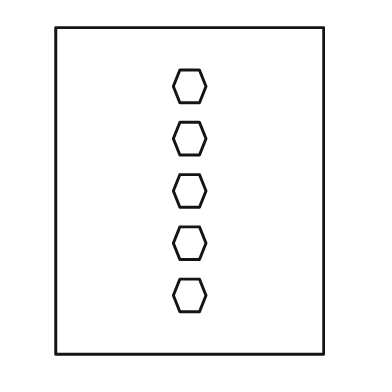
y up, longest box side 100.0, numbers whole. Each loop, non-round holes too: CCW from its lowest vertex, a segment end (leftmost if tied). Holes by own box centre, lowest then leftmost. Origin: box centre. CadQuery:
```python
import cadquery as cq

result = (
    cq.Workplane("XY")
    .moveTo(-41.0, -50.0)
    .lineTo(41.0, -50.0)
    .lineTo(41.0, 50.0)
    .lineTo(-41.0, 50.0)
    .close()
    .moveTo(-3.0, -37.0)
    .lineTo(3.0, -37.0)
    .lineTo(5.0, -32.0)
    .lineTo(3.0, -27.0)
    .lineTo(-3.0, -27.0)
    .lineTo(-5.0, -32.0)
    .close()
    .moveTo(-3.0, -21.0)
    .lineTo(3.0, -21.0)
    .lineTo(5.0, -16.0)
    .lineTo(3.0, -11.0)
    .lineTo(-3.0, -11.0)
    .lineTo(-5.0, -16.0)
    .close()
    .moveTo(-3.0, -5.0)
    .lineTo(3.0, -5.0)
    .lineTo(5.0, 0.0)
    .lineTo(3.0, 5.0)
    .lineTo(-3.0, 5.0)
    .lineTo(-5.0, 0.0)
    .close()
    .moveTo(-3.0, 11.0)
    .lineTo(3.0, 11.0)
    .lineTo(5.0, 16.0)
    .lineTo(3.0, 21.0)
    .lineTo(-3.0, 21.0)
    .lineTo(-5.0, 16.0)
    .close()
    .moveTo(-3.0, 27.0)
    .lineTo(3.0, 27.0)
    .lineTo(5.0, 32.0)
    .lineTo(3.0, 37.0)
    .lineTo(-3.0, 37.0)
    .lineTo(-5.0, 32.0)
    .close()
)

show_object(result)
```